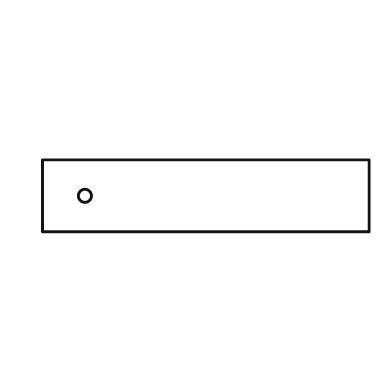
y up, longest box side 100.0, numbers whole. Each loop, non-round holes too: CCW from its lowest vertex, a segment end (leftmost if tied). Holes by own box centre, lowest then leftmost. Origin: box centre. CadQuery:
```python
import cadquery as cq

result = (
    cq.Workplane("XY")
    .moveTo(-50.0, -11.0)
    .lineTo(50.0, -11.0)
    .lineTo(50.0, 11.0)
    .lineTo(-50.0, 11.0)
    .close()
    .moveTo(-37.0, 0.0)
    .circle(2.0)
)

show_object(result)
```